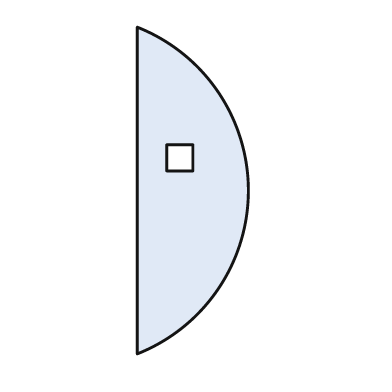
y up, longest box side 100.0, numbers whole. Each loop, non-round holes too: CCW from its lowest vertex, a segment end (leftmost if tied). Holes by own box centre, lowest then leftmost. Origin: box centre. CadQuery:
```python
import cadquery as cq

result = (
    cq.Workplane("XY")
    .moveTo(-17.0, -50.0)
    .threePointArc((17.0, 0.0), (-17.0, 50.0))
    .close()
    .moveTo(-8.0, 6.0)
    .lineTo(0.0, 6.0)
    .lineTo(0.0, 14.0)
    .lineTo(-8.0, 14.0)
    .close()
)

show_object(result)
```